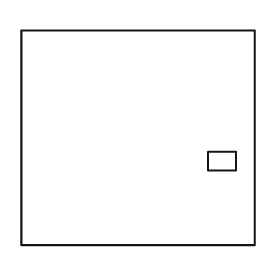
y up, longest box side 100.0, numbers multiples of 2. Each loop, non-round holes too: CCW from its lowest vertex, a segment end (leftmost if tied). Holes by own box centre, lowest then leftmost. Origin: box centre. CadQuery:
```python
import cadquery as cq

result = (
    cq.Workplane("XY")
    .moveTo(-50.0, -46.0)
    .lineTo(50.0, -46.0)
    .lineTo(50.0, 46.0)
    .lineTo(-50.0, 46.0)
    .close()
    .moveTo(30.0, -14.0)
    .lineTo(42.0, -14.0)
    .lineTo(42.0, -6.0)
    .lineTo(30.0, -6.0)
    .close()
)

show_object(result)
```